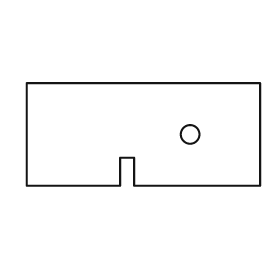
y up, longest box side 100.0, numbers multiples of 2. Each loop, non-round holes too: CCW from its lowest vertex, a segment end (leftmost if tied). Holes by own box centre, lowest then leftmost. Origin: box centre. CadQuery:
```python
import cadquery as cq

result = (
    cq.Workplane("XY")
    .moveTo(-50.0, -22.0)
    .lineTo(-10.0, -22.0)
    .lineTo(-10.0, -10.0)
    .lineTo(-4.0, -10.0)
    .lineTo(-4.0, -22.0)
    .lineTo(50.0, -22.0)
    .lineTo(50.0, 22.0)
    .lineTo(-50.0, 22.0)
    .close()
    .moveTo(20.0, 0.0)
    .circle(4.0)
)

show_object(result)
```